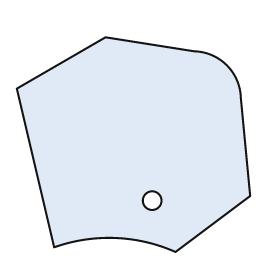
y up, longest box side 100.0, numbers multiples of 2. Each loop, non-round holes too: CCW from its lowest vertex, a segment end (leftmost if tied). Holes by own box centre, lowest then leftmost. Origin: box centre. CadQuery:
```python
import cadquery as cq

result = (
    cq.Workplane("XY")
    .moveTo(18.0, -46.0)
    .lineTo(50.0, -22.0)
    .lineTo(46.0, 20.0)
    .threePointArc((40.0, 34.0), (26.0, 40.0))
    .lineTo(-12.0, 46.0)
    .lineTo(-50.0, 24.0)
    .lineTo(-34.0, -44.0)
    .threePointArc((-8.0, -40.0), (18.0, -46.0))
    .close()
    .moveTo(8.0, -24.0)
    .circle(4.0)
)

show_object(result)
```